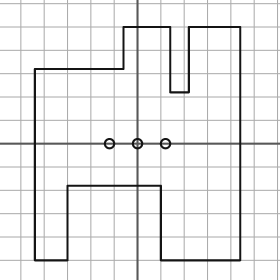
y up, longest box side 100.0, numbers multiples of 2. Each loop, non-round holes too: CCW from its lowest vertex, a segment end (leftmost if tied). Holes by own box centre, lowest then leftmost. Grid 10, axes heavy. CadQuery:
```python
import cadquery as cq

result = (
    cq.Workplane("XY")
    .moveTo(-44.0, -50.0)
    .lineTo(-30.0, -50.0)
    .lineTo(-30.0, -18.0)
    .lineTo(10.0, -18.0)
    .lineTo(10.0, -50.0)
    .lineTo(44.0, -50.0)
    .lineTo(44.0, 50.0)
    .lineTo(22.0, 50.0)
    .lineTo(22.0, 22.0)
    .lineTo(14.0, 22.0)
    .lineTo(14.0, 50.0)
    .lineTo(-6.0, 50.0)
    .lineTo(-6.0, 32.0)
    .lineTo(-44.0, 32.0)
    .close()
    .moveTo(-12.0, 0.0)
    .circle(2.0)
    .moveTo(0.0, 0.0)
    .circle(2.0)
    .moveTo(12.0, 0.0)
    .circle(2.0)
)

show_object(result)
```